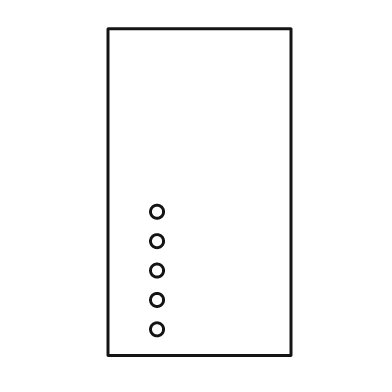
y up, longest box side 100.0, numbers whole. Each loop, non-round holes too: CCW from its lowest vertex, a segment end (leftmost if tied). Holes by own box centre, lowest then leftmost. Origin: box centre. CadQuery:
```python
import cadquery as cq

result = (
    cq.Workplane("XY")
    .moveTo(-28.0, -50.0)
    .lineTo(28.0, -50.0)
    .lineTo(28.0, 50.0)
    .lineTo(-28.0, 50.0)
    .close()
    .moveTo(-13.0, -42.0)
    .circle(2.0)
    .moveTo(-13.0, -33.0)
    .circle(2.0)
    .moveTo(-13.0, -24.0)
    .circle(2.0)
    .moveTo(-13.0, -15.0)
    .circle(2.0)
    .moveTo(-13.0, -6.0)
    .circle(2.0)
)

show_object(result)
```